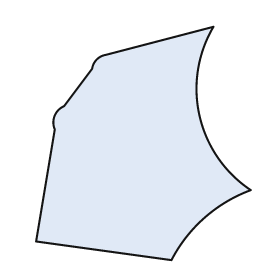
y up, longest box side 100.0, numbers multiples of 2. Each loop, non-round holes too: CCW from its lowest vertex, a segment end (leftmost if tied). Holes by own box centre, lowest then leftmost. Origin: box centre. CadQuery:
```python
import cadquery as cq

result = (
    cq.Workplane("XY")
    .moveTo(12.0, -50.0)
    .threePointArc((26.0, -32.0), (46.0, -20.0))
    .threePointArc((24.0, 12.0), (30.0, 50.0))
    .lineTo(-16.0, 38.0)
    .threePointArc((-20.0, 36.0), (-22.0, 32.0))
    .lineTo(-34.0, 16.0)
    .threePointArc((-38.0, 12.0), (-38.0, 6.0))
    .lineTo(-46.0, -42.0)
    .close()
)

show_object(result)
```